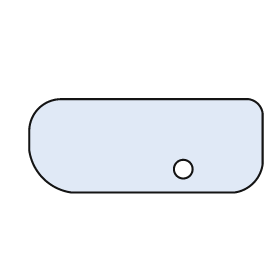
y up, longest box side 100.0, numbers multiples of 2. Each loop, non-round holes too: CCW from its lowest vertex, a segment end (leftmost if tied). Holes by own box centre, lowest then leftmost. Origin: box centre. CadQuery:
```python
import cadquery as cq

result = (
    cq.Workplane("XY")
    .moveTo(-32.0, -20.0)
    .lineTo(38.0, -20.0)
    .threePointArc((46.0, -16.0), (50.0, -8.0))
    .lineTo(50.0, 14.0)
    .threePointArc((48.0, 18.0), (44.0, 20.0))
    .lineTo(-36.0, 20.0)
    .threePointArc((-46.0, 16.0), (-50.0, 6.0))
    .lineTo(-50.0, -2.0)
    .threePointArc((-44.0, -14.0), (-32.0, -20.0))
    .close()
    .moveTo(16.0, -10.0)
    .circle(4.0)
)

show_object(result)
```